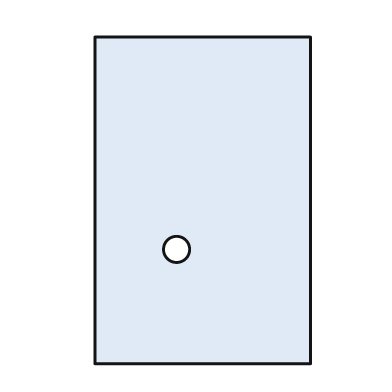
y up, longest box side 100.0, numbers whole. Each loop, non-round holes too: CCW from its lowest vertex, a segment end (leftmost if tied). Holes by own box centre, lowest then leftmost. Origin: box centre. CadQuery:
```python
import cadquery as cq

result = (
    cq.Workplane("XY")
    .moveTo(-33.0, -50.0)
    .lineTo(33.0, -50.0)
    .lineTo(33.0, 50.0)
    .lineTo(-33.0, 50.0)
    .close()
    .moveTo(-8.0, -15.0)
    .circle(4.0)
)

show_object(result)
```